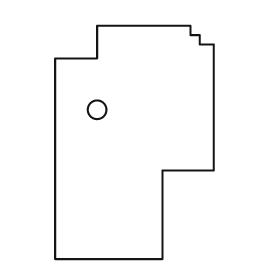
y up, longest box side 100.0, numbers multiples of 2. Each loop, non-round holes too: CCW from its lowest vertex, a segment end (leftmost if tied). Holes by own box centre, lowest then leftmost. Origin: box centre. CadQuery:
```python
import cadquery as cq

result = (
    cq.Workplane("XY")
    .moveTo(-34.0, -50.0)
    .lineTo(12.0, -50.0)
    .lineTo(12.0, -12.0)
    .lineTo(34.0, -12.0)
    .lineTo(34.0, 42.0)
    .lineTo(28.0, 42.0)
    .lineTo(28.0, 46.0)
    .lineTo(24.0, 46.0)
    .lineTo(24.0, 50.0)
    .lineTo(-16.0, 50.0)
    .lineTo(-16.0, 36.0)
    .lineTo(-34.0, 36.0)
    .close()
    .moveTo(-16.0, 14.0)
    .circle(4.0)
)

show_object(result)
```